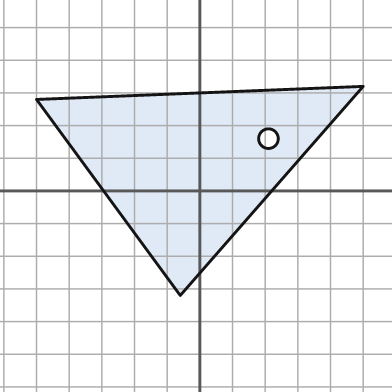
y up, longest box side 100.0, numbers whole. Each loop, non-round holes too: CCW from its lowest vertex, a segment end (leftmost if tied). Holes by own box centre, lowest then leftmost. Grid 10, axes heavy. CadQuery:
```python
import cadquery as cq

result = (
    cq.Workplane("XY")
    .moveTo(-6.0, -32.0)
    .lineTo(50.0, 32.0)
    .lineTo(-50.0, 28.0)
    .close()
    .moveTo(21.0, 16.0)
    .circle(3.0)
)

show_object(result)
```